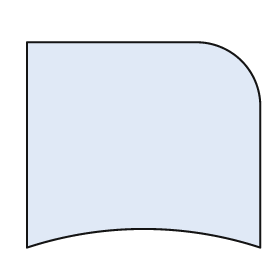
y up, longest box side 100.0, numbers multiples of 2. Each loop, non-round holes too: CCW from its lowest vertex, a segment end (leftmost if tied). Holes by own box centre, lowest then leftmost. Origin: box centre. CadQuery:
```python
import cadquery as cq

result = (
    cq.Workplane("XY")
    .moveTo(-50.0, -44.0)
    .threePointArc((0.0, -36.0), (50.0, -44.0))
    .lineTo(50.0, 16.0)
    .threePointArc((42.0, 36.0), (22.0, 44.0))
    .lineTo(-50.0, 44.0)
    .close()
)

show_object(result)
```